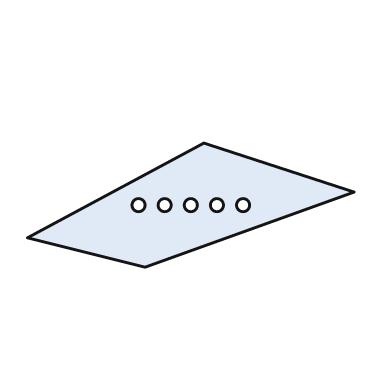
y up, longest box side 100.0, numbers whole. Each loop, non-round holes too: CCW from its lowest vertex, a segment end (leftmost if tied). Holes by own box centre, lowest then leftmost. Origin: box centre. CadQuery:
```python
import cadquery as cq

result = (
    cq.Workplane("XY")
    .moveTo(-14.0, -19.0)
    .lineTo(50.0, 4.0)
    .lineTo(4.0, 19.0)
    .lineTo(-50.0, -10.0)
    .close()
    .moveTo(-16.0, 0.0)
    .circle(2.0)
    .moveTo(-8.0, 0.0)
    .circle(2.0)
    .moveTo(0.0, 0.0)
    .circle(2.0)
    .moveTo(8.0, 0.0)
    .circle(2.0)
    .moveTo(16.0, 0.0)
    .circle(2.0)
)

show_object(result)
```